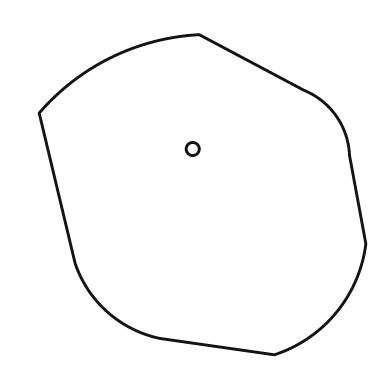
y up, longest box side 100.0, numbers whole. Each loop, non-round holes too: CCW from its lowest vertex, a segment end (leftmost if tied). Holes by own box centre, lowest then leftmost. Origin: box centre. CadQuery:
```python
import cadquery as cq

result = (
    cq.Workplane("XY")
    .moveTo(22.0, -49.0)
    .threePointArc((41.0, -36.0), (50.0, -15.0))
    .lineTo(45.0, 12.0)
    .threePointArc((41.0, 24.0), (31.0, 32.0))
    .lineTo(-1.0, 49.0)
    .threePointArc((-28.0, 42.0), (-50.0, 25.0))
    .lineTo(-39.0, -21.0)
    .threePointArc((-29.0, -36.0), (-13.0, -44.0))
    .close()
    .moveTo(-3.0, 14.0)
    .circle(2.0)
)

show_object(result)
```